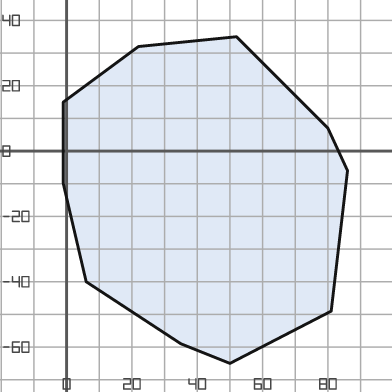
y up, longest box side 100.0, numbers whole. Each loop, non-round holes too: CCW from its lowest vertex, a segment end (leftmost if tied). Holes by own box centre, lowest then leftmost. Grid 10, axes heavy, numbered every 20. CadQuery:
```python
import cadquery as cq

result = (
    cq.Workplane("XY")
    .moveTo(50.0, -65.0)
    .lineTo(81.0, -49.0)
    .lineTo(86.0, -6.0)
    .lineTo(80.0, 7.0)
    .lineTo(52.0, 35.0)
    .lineTo(22.0, 32.0)
    .lineTo(-1.0, 15.0)
    .lineTo(-1.0, -10.0)
    .lineTo(6.0, -40.0)
    .lineTo(35.0, -59.0)
    .close()
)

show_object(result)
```